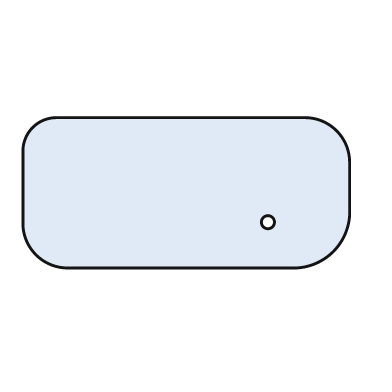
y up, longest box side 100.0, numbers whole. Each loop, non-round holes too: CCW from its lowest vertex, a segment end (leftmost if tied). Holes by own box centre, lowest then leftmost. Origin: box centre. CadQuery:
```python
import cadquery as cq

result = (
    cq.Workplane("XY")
    .moveTo(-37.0, -23.0)
    .lineTo(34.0, -23.0)
    .threePointArc((45.0, -18.0), (50.0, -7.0))
    .lineTo(50.0, 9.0)
    .threePointArc((46.0, 19.0), (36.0, 23.0))
    .lineTo(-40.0, 23.0)
    .threePointArc((-47.0, 20.0), (-50.0, 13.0))
    .lineTo(-50.0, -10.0)
    .threePointArc((-46.0, -19.0), (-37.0, -23.0))
    .close()
    .moveTo(25.0, -9.0)
    .circle(2.0)
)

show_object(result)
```